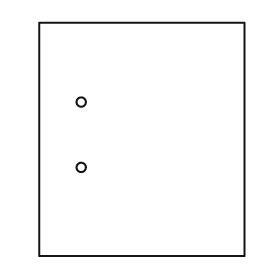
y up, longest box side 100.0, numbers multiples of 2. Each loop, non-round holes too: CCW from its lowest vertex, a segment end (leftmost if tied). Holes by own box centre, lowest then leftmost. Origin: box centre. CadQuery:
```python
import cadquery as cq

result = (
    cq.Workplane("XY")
    .moveTo(-44.0, -50.0)
    .lineTo(44.0, -50.0)
    .lineTo(44.0, 50.0)
    .lineTo(-44.0, 50.0)
    .close()
    .moveTo(-26.0, -12.0)
    .circle(2.0)
    .moveTo(-26.0, 16.0)
    .circle(2.0)
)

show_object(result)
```